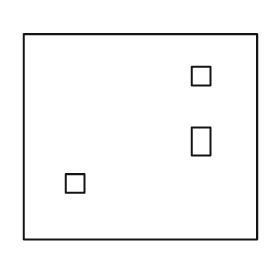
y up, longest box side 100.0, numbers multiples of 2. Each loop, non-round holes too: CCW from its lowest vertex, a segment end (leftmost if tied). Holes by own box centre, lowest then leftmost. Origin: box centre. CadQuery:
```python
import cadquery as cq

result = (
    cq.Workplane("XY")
    .moveTo(-50.0, -44.0)
    .lineTo(50.0, -44.0)
    .lineTo(50.0, 44.0)
    .lineTo(-50.0, 44.0)
    .close()
    .moveTo(-32.0, -24.0)
    .lineTo(-24.0, -24.0)
    .lineTo(-24.0, -16.0)
    .lineTo(-32.0, -16.0)
    .close()
    .moveTo(22.0, -8.0)
    .lineTo(30.0, -8.0)
    .lineTo(30.0, 4.0)
    .lineTo(22.0, 4.0)
    .close()
    .moveTo(22.0, 22.0)
    .lineTo(30.0, 22.0)
    .lineTo(30.0, 30.0)
    .lineTo(22.0, 30.0)
    .close()
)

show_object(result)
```